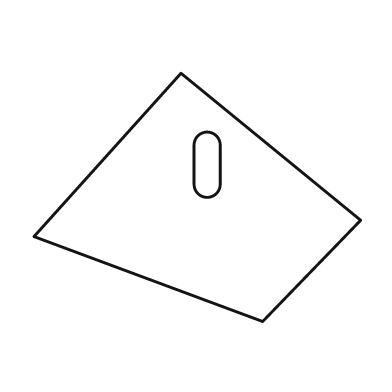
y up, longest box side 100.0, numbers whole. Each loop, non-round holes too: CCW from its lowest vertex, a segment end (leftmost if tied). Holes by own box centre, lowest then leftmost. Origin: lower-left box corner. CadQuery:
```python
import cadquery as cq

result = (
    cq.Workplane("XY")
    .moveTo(70.0, 0.0)
    .lineTo(100.0, 31.0)
    .lineTo(45.0, 76.0)
    .lineTo(0.0, 26.0)
    .close()
    .moveTo(49.0, 42.0)
    .threePointArc((53.0, 38.0), (57.0, 42.0))
    .lineTo(57.0, 54.0)
    .threePointArc((53.0, 58.0), (49.0, 54.0))
    .close()
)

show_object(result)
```